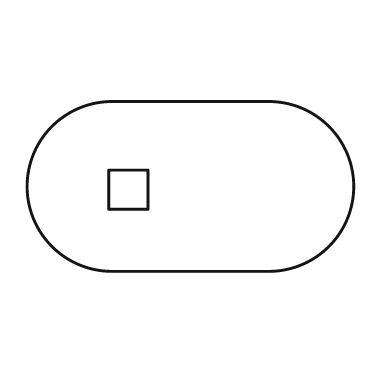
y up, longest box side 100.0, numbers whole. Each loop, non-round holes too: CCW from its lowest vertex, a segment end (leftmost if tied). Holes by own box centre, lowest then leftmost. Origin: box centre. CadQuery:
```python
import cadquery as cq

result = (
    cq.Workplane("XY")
    .moveTo(-24.0, -26.0)
    .lineTo(24.0, -26.0)
    .threePointArc((50.0, 0.0), (24.0, 26.0))
    .lineTo(-24.0, 26.0)
    .threePointArc((-50.0, 0.0), (-24.0, -26.0))
    .close()
    .moveTo(-25.0, -7.0)
    .lineTo(-13.0, -7.0)
    .lineTo(-13.0, 5.0)
    .lineTo(-25.0, 5.0)
    .close()
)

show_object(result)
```